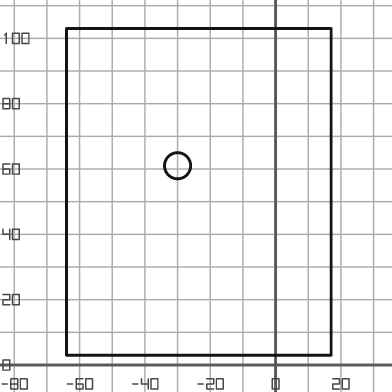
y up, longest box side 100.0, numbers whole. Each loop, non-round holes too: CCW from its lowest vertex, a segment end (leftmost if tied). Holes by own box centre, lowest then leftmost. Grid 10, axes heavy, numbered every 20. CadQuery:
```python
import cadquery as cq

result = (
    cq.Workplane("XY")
    .moveTo(-64.0, 3.0)
    .lineTo(17.0, 3.0)
    .lineTo(17.0, 103.0)
    .lineTo(-64.0, 103.0)
    .close()
    .moveTo(-30.0, 61.0)
    .circle(4.0)
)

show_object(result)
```